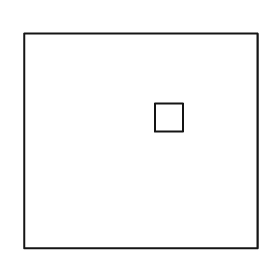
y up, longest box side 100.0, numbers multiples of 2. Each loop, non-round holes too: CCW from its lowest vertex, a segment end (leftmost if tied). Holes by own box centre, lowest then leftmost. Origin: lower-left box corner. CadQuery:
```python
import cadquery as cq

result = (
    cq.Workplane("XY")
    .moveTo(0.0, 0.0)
    .lineTo(100.0, 0.0)
    .lineTo(100.0, 92.0)
    .lineTo(0.0, 92.0)
    .close()
    .moveTo(56.0, 50.0)
    .lineTo(68.0, 50.0)
    .lineTo(68.0, 62.0)
    .lineTo(56.0, 62.0)
    .close()
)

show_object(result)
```